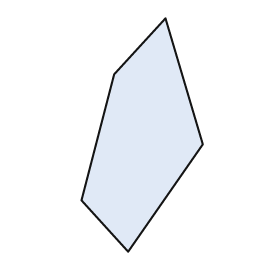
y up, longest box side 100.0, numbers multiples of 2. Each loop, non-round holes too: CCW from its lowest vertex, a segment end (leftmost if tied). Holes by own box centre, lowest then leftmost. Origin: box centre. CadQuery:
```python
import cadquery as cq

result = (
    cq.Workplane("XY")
    .moveTo(-6.0, -50.0)
    .lineTo(26.0, -4.0)
    .lineTo(10.0, 50.0)
    .lineTo(-12.0, 26.0)
    .lineTo(-26.0, -28.0)
    .close()
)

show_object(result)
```